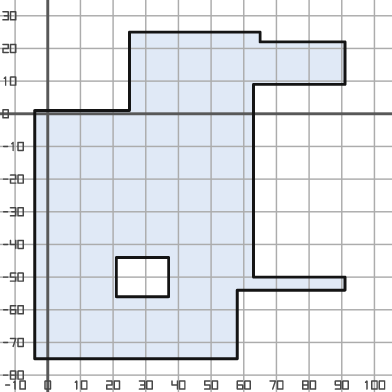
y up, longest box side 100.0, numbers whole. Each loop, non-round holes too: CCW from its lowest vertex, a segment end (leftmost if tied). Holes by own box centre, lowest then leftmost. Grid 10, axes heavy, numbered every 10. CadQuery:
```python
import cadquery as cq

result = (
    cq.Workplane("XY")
    .moveTo(-4.0, -75.0)
    .lineTo(58.0, -75.0)
    .lineTo(58.0, -54.0)
    .lineTo(91.0, -54.0)
    .lineTo(91.0, -50.0)
    .lineTo(63.0, -50.0)
    .lineTo(63.0, 9.0)
    .lineTo(91.0, 9.0)
    .lineTo(91.0, 22.0)
    .lineTo(65.0, 22.0)
    .lineTo(65.0, 25.0)
    .lineTo(25.0, 25.0)
    .lineTo(25.0, 1.0)
    .lineTo(-4.0, 1.0)
    .close()
    .moveTo(21.0, -56.0)
    .lineTo(37.0, -56.0)
    .lineTo(37.0, -44.0)
    .lineTo(21.0, -44.0)
    .close()
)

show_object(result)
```